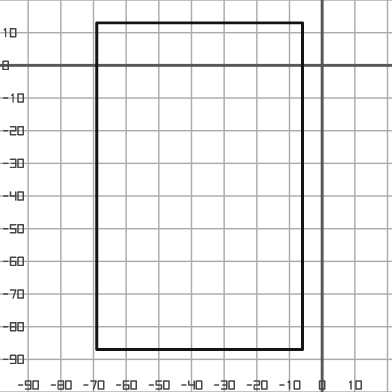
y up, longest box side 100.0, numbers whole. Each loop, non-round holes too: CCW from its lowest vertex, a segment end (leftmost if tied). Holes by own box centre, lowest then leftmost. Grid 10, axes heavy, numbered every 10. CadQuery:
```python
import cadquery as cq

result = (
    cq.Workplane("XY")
    .moveTo(-69.0, -87.0)
    .lineTo(-6.0, -87.0)
    .lineTo(-6.0, 13.0)
    .lineTo(-69.0, 13.0)
    .close()
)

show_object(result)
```